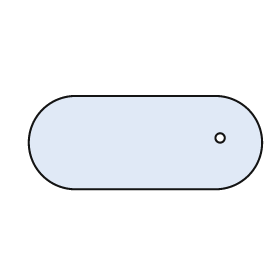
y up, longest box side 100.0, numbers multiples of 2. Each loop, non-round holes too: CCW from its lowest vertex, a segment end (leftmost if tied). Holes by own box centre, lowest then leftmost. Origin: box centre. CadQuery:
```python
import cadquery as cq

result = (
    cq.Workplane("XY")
    .moveTo(-30.0, -20.0)
    .lineTo(30.0, -20.0)
    .threePointArc((50.0, 0.0), (30.0, 20.0))
    .lineTo(-30.0, 20.0)
    .threePointArc((-50.0, 0.0), (-30.0, -20.0))
    .close()
    .moveTo(32.0, 2.0)
    .circle(2.0)
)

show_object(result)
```